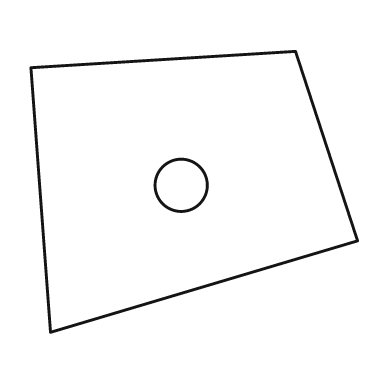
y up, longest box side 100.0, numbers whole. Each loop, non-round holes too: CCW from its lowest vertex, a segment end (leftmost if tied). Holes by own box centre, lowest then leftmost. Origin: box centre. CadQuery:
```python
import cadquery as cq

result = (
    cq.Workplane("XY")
    .moveTo(-44.0, -43.0)
    .lineTo(50.0, -15.0)
    .lineTo(31.0, 43.0)
    .lineTo(-50.0, 38.0)
    .close()
    .moveTo(-4.0, 2.0)
    .circle(8.0)
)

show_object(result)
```